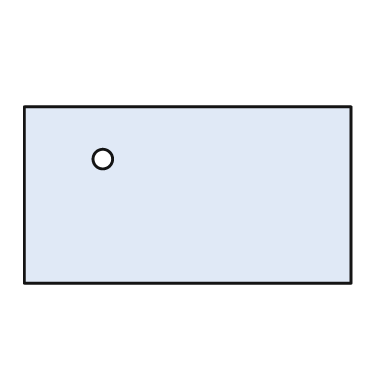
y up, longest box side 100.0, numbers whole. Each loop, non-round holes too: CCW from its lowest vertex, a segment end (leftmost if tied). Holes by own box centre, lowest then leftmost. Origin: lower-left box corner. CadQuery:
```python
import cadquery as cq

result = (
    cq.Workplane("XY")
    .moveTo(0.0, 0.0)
    .lineTo(100.0, 0.0)
    .lineTo(100.0, 54.0)
    .lineTo(0.0, 54.0)
    .close()
    .moveTo(24.0, 38.0)
    .circle(3.0)
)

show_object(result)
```